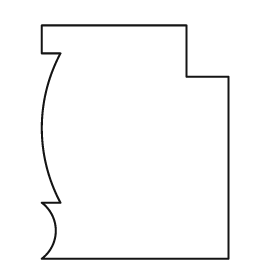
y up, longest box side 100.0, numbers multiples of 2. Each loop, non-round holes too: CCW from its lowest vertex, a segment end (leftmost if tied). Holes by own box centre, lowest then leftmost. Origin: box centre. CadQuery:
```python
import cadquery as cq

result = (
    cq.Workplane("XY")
    .moveTo(-40.0, -50.0)
    .lineTo(40.0, -50.0)
    .lineTo(40.0, 28.0)
    .lineTo(22.0, 28.0)
    .lineTo(22.0, 50.0)
    .lineTo(-40.0, 50.0)
    .lineTo(-40.0, 38.0)
    .lineTo(-32.0, 38.0)
    .threePointArc((-40.0, 6.0), (-32.0, -26.0))
    .lineTo(-40.0, -26.0)
    .threePointArc((-34.0, -38.0), (-40.0, -50.0))
    .close()
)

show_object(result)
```